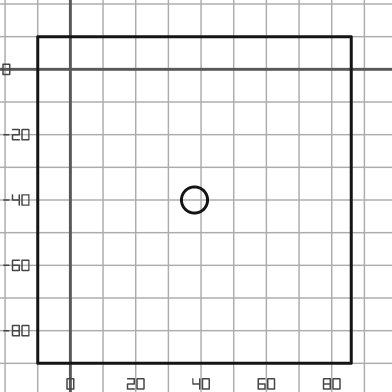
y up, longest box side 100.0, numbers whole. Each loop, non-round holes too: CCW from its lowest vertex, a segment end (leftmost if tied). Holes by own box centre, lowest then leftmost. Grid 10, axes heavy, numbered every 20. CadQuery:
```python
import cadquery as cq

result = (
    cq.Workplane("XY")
    .moveTo(-10.0, -90.0)
    .lineTo(86.0, -90.0)
    .lineTo(86.0, 10.0)
    .lineTo(-10.0, 10.0)
    .close()
    .moveTo(38.0, -40.0)
    .circle(4.0)
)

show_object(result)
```